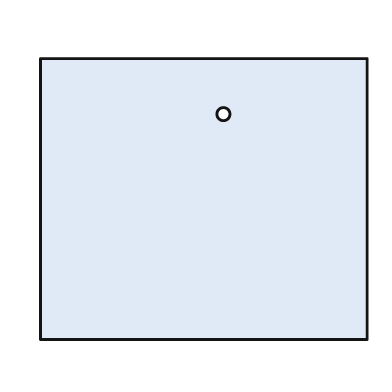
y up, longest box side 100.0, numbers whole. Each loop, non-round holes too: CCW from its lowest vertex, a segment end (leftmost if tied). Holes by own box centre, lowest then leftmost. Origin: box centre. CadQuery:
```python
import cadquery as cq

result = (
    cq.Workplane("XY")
    .moveTo(-50.0, -43.0)
    .lineTo(50.0, -43.0)
    .lineTo(50.0, 43.0)
    .lineTo(-50.0, 43.0)
    .close()
    .moveTo(6.0, 26.0)
    .circle(2.0)
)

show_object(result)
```